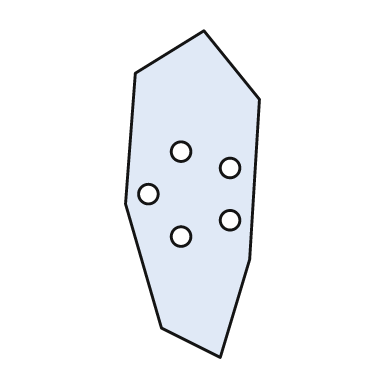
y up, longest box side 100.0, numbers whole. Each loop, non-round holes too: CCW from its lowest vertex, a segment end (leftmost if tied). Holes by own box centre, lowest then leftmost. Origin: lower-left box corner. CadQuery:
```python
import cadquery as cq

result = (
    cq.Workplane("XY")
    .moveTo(29.0, 0.0)
    .lineTo(38.0, 30.0)
    .lineTo(41.0, 79.0)
    .lineTo(24.0, 100.0)
    .lineTo(3.0, 87.0)
    .lineTo(0.0, 47.0)
    .lineTo(11.0, 9.0)
    .close()
    .moveTo(17.0, 37.0)
    .circle(3.0)
    .moveTo(32.0, 42.0)
    .circle(3.0)
    .moveTo(7.0, 50.0)
    .circle(3.0)
    .moveTo(32.0, 58.0)
    .circle(3.0)
    .moveTo(17.0, 63.0)
    .circle(3.0)
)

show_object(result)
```